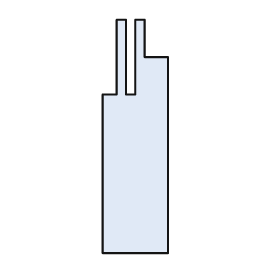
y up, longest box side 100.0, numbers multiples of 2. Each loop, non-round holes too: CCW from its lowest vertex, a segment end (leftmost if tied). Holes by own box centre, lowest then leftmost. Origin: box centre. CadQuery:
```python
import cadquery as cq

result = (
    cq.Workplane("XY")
    .moveTo(-14.0, -50.0)
    .lineTo(14.0, -50.0)
    .lineTo(14.0, 34.0)
    .lineTo(4.0, 34.0)
    .lineTo(4.0, 50.0)
    .lineTo(0.0, 50.0)
    .lineTo(0.0, 18.0)
    .lineTo(-4.0, 18.0)
    .lineTo(-4.0, 50.0)
    .lineTo(-8.0, 50.0)
    .lineTo(-8.0, 18.0)
    .lineTo(-14.0, 18.0)
    .close()
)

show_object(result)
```